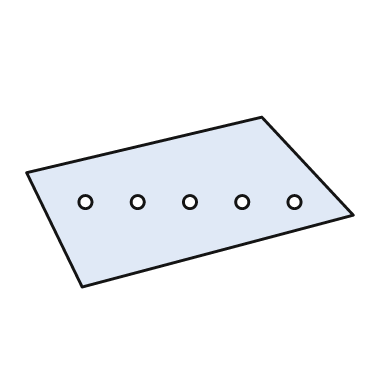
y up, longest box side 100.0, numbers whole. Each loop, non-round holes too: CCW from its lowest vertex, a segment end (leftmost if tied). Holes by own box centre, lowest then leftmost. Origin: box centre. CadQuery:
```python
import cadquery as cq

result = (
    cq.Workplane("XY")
    .moveTo(-33.0, -26.0)
    .lineTo(50.0, -4.0)
    .lineTo(22.0, 26.0)
    .lineTo(-50.0, 9.0)
    .close()
    .moveTo(-32.0, 0.0)
    .circle(2.0)
    .moveTo(-16.0, 0.0)
    .circle(2.0)
    .moveTo(0.0, 0.0)
    .circle(2.0)
    .moveTo(16.0, 0.0)
    .circle(2.0)
    .moveTo(32.0, 0.0)
    .circle(2.0)
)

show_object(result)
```